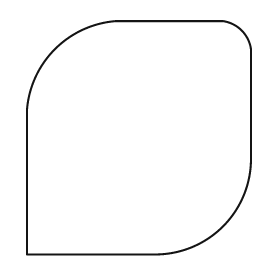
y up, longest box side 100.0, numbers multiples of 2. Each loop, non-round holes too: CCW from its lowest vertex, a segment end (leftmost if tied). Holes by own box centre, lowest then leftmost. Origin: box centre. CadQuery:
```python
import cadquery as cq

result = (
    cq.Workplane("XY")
    .moveTo(-48.0, -50.0)
    .lineTo(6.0, -50.0)
    .threePointArc((36.0, -38.0), (48.0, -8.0))
    .lineTo(48.0, 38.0)
    .threePointArc((44.0, 46.0), (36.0, 50.0))
    .lineTo(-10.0, 50.0)
    .threePointArc((-36.0, 38.0), (-48.0, 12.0))
    .close()
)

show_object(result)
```